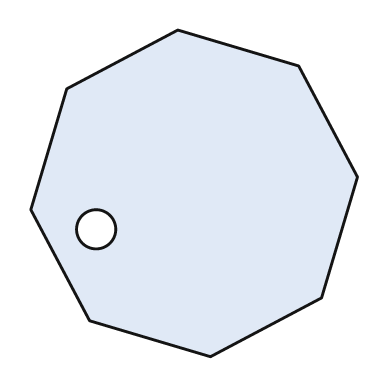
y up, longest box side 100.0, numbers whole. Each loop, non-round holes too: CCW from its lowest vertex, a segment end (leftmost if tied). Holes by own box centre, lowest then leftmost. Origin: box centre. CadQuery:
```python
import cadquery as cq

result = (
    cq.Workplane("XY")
    .moveTo(5.0, -50.0)
    .lineTo(39.0, -32.0)
    .lineTo(50.0, 5.0)
    .lineTo(32.0, 39.0)
    .lineTo(-5.0, 50.0)
    .lineTo(-39.0, 32.0)
    .lineTo(-50.0, -5.0)
    .lineTo(-32.0, -39.0)
    .close()
    .moveTo(-30.0, -11.0)
    .circle(6.0)
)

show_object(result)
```